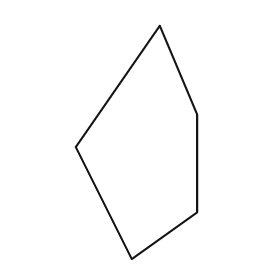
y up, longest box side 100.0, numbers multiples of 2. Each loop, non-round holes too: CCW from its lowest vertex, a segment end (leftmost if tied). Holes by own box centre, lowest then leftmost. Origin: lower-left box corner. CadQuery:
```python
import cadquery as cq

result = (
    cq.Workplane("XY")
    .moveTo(24.0, 0.0)
    .lineTo(52.0, 20.0)
    .lineTo(52.0, 62.0)
    .lineTo(36.0, 100.0)
    .lineTo(0.0, 48.0)
    .close()
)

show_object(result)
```